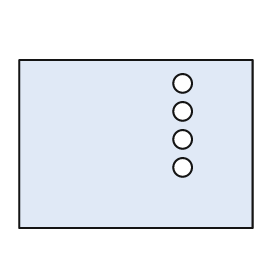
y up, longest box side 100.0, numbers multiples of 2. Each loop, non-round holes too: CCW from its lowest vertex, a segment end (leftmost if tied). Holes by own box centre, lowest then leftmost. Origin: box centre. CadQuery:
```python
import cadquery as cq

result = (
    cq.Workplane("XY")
    .moveTo(-50.0, -36.0)
    .lineTo(50.0, -36.0)
    .lineTo(50.0, 36.0)
    .lineTo(-50.0, 36.0)
    .close()
    .moveTo(20.0, -10.0)
    .circle(4.0)
    .moveTo(20.0, 2.0)
    .circle(4.0)
    .moveTo(20.0, 14.0)
    .circle(4.0)
    .moveTo(20.0, 26.0)
    .circle(4.0)
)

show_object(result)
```